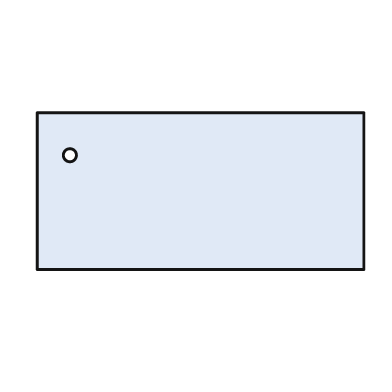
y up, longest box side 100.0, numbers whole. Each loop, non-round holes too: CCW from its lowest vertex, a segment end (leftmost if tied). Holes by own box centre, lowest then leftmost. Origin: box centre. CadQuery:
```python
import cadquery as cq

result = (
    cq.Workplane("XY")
    .moveTo(-50.0, -24.0)
    .lineTo(50.0, -24.0)
    .lineTo(50.0, 24.0)
    .lineTo(-50.0, 24.0)
    .close()
    .moveTo(-40.0, 11.0)
    .circle(2.0)
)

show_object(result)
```